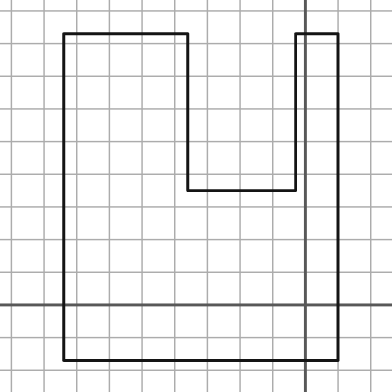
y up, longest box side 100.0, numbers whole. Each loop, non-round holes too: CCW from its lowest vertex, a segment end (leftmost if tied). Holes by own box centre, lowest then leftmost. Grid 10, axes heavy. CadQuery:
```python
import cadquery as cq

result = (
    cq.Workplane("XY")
    .moveTo(-74.0, -17.0)
    .lineTo(10.0, -17.0)
    .lineTo(10.0, 83.0)
    .lineTo(-3.0, 83.0)
    .lineTo(-3.0, 35.0)
    .lineTo(-36.0, 35.0)
    .lineTo(-36.0, 83.0)
    .lineTo(-74.0, 83.0)
    .close()
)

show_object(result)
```